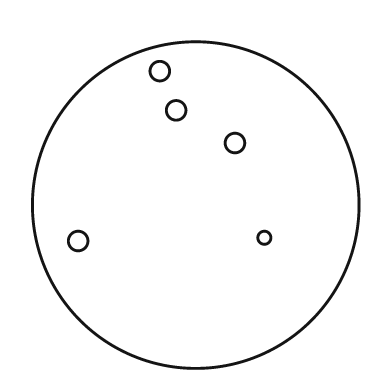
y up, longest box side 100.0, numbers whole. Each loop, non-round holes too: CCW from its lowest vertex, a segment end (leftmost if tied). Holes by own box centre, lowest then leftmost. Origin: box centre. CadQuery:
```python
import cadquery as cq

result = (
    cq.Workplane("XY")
    .moveTo(0.0, 0.0)
    .circle(50.0)
    .moveTo(-36.0, -11.0)
    .circle(3.0)
    .moveTo(21.0, -10.0)
    .circle(2.0)
    .moveTo(12.0, 19.0)
    .circle(3.0)
    .moveTo(-6.0, 29.0)
    .circle(3.0)
    .moveTo(-11.0, 41.0)
    .circle(3.0)
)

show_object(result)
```